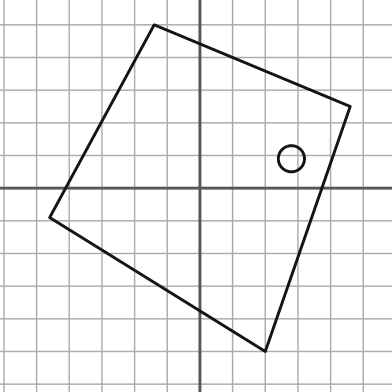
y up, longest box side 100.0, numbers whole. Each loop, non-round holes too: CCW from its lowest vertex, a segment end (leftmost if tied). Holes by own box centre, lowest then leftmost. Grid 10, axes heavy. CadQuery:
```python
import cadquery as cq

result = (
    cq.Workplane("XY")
    .moveTo(20.0, -50.0)
    .lineTo(46.0, 25.0)
    .lineTo(-14.0, 50.0)
    .lineTo(-46.0, -9.0)
    .close()
    .moveTo(28.0, 9.0)
    .circle(4.0)
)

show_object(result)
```